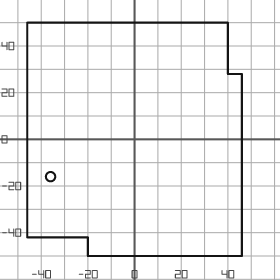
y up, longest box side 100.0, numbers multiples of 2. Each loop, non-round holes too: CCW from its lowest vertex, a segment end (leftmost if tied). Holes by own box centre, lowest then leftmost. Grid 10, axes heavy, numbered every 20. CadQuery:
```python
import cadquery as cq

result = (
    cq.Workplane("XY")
    .moveTo(-20.0, -50.0)
    .lineTo(46.0, -50.0)
    .lineTo(46.0, 28.0)
    .lineTo(40.0, 28.0)
    .lineTo(40.0, 50.0)
    .lineTo(-46.0, 50.0)
    .lineTo(-46.0, -42.0)
    .lineTo(-20.0, -42.0)
    .close()
    .moveTo(-36.0, -16.0)
    .circle(2.0)
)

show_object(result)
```